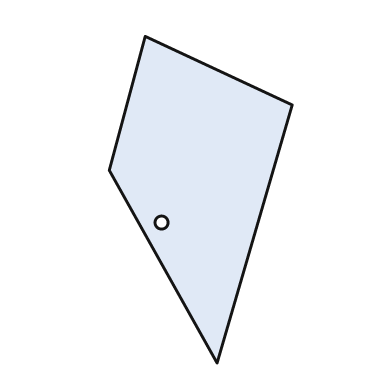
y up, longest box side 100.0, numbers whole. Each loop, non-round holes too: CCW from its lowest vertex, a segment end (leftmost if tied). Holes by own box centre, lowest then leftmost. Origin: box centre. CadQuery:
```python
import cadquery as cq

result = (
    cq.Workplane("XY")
    .moveTo(5.0, -50.0)
    .lineTo(28.0, 29.0)
    .lineTo(-17.0, 50.0)
    .lineTo(-28.0, 9.0)
    .close()
    .moveTo(-12.0, -7.0)
    .circle(2.0)
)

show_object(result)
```